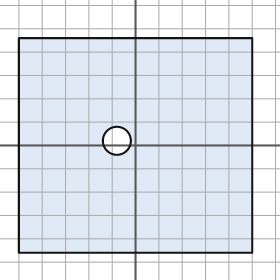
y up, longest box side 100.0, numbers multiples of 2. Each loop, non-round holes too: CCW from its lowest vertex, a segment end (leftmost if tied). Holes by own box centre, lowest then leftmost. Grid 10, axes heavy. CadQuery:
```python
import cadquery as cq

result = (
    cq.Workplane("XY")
    .moveTo(-50.0, -46.0)
    .lineTo(50.0, -46.0)
    .lineTo(50.0, 46.0)
    .lineTo(-50.0, 46.0)
    .close()
    .moveTo(-8.0, 2.0)
    .circle(6.0)
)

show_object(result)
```